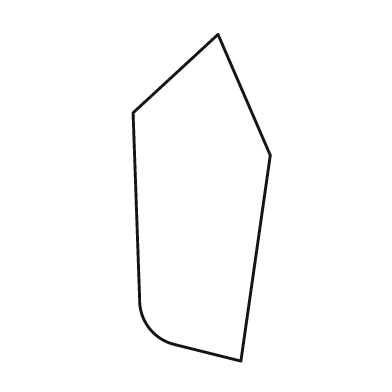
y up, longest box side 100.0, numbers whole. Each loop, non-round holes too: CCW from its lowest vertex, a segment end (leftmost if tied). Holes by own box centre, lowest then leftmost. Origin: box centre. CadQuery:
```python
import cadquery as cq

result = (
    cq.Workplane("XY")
    .moveTo(12.0, -50.0)
    .lineTo(21.0, 13.0)
    .lineTo(5.0, 50.0)
    .lineTo(-21.0, 26.0)
    .lineTo(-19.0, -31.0)
    .threePointArc((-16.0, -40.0), (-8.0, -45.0))
    .close()
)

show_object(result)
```